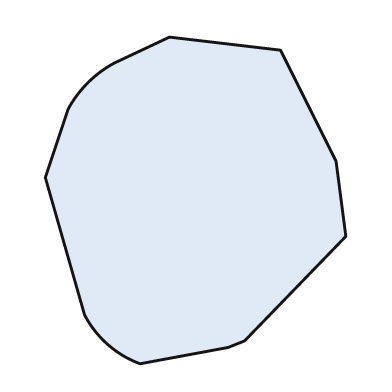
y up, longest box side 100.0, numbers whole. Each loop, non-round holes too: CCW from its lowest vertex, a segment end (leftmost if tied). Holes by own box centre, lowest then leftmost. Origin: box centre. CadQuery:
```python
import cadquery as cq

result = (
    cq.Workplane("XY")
    .moveTo(-17.0, -50.0)
    .lineTo(10.0, -45.0)
    .lineTo(15.0, -43.0)
    .lineTo(46.0, -11.0)
    .lineTo(43.0, 12.0)
    .lineTo(26.0, 46.0)
    .lineTo(-8.0, 50.0)
    .lineTo(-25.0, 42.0)
    .threePointArc((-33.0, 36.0), (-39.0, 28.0))
    .lineTo(-46.0, 7.0)
    .lineTo(-34.0, -35.0)
    .threePointArc((-27.0, -44.0), (-17.0, -50.0))
    .close()
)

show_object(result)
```